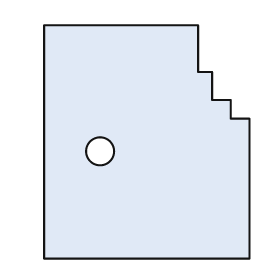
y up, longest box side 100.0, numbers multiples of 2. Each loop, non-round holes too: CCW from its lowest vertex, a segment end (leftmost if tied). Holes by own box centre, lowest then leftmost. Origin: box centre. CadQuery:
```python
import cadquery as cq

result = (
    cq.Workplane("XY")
    .moveTo(-44.0, -50.0)
    .lineTo(44.0, -50.0)
    .lineTo(44.0, 10.0)
    .lineTo(36.0, 10.0)
    .lineTo(36.0, 18.0)
    .lineTo(28.0, 18.0)
    .lineTo(28.0, 30.0)
    .lineTo(22.0, 30.0)
    .lineTo(22.0, 50.0)
    .lineTo(-44.0, 50.0)
    .close()
    .moveTo(-20.0, -4.0)
    .circle(6.0)
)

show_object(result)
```